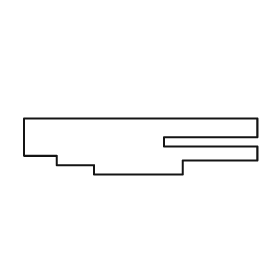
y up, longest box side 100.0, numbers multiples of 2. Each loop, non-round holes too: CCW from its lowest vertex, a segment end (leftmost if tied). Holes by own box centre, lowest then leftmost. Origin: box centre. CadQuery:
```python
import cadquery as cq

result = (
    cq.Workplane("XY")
    .moveTo(-20.0, -12.0)
    .lineTo(18.0, -12.0)
    .lineTo(18.0, -6.0)
    .lineTo(50.0, -6.0)
    .lineTo(50.0, 0.0)
    .lineTo(10.0, 0.0)
    .lineTo(10.0, 4.0)
    .lineTo(50.0, 4.0)
    .lineTo(50.0, 12.0)
    .lineTo(-50.0, 12.0)
    .lineTo(-50.0, -4.0)
    .lineTo(-36.0, -4.0)
    .lineTo(-36.0, -8.0)
    .lineTo(-20.0, -8.0)
    .close()
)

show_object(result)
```